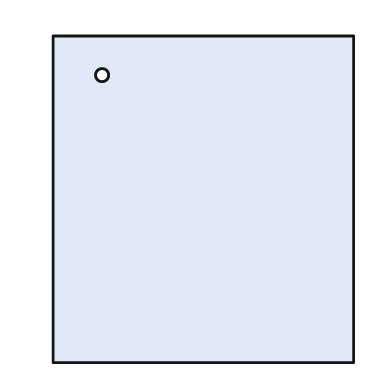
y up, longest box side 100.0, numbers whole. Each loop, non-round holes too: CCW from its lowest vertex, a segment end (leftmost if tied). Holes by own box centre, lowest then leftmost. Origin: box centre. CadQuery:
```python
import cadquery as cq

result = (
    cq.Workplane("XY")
    .moveTo(-46.0, -50.0)
    .lineTo(46.0, -50.0)
    .lineTo(46.0, 50.0)
    .lineTo(-46.0, 50.0)
    .close()
    .moveTo(-31.0, 38.0)
    .circle(2.0)
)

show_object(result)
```